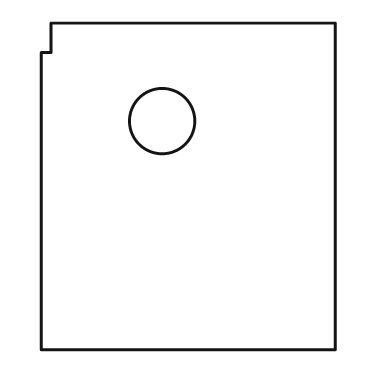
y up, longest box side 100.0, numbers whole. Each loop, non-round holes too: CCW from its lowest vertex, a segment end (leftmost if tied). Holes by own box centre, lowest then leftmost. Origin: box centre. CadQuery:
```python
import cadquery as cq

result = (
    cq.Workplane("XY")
    .moveTo(-45.0, -50.0)
    .lineTo(45.0, -50.0)
    .lineTo(45.0, 50.0)
    .lineTo(-42.0, 50.0)
    .lineTo(-42.0, 41.0)
    .lineTo(-45.0, 41.0)
    .close()
    .moveTo(-8.0, 20.0)
    .circle(10.0)
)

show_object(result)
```